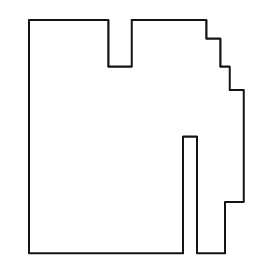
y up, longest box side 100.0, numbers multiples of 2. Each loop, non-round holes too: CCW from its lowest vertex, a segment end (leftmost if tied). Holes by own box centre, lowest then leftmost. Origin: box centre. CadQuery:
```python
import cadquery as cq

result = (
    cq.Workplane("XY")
    .moveTo(-46.0, -50.0)
    .lineTo(20.0, -50.0)
    .lineTo(20.0, 0.0)
    .lineTo(26.0, 0.0)
    .lineTo(26.0, -50.0)
    .lineTo(38.0, -50.0)
    .lineTo(38.0, -28.0)
    .lineTo(46.0, -28.0)
    .lineTo(46.0, 20.0)
    .lineTo(40.0, 20.0)
    .lineTo(40.0, 30.0)
    .lineTo(36.0, 30.0)
    .lineTo(36.0, 42.0)
    .lineTo(30.0, 42.0)
    .lineTo(30.0, 50.0)
    .lineTo(-2.0, 50.0)
    .lineTo(-2.0, 30.0)
    .lineTo(-12.0, 30.0)
    .lineTo(-12.0, 50.0)
    .lineTo(-46.0, 50.0)
    .close()
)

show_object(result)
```